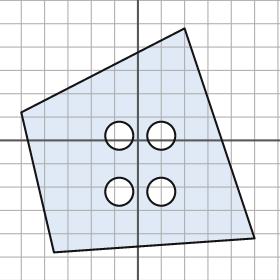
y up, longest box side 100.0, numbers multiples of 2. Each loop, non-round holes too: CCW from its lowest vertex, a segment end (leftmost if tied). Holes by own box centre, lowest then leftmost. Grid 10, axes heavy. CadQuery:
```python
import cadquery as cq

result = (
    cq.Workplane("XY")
    .moveTo(-36.0, -48.0)
    .lineTo(50.0, -42.0)
    .lineTo(20.0, 48.0)
    .lineTo(-50.0, 12.0)
    .close()
    .moveTo(-8.0, -22.0)
    .circle(6.0)
    .moveTo(10.0, -22.0)
    .circle(6.0)
    .moveTo(-8.0, 2.0)
    .circle(6.0)
    .moveTo(10.0, 2.0)
    .circle(6.0)
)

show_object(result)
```